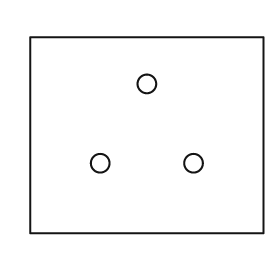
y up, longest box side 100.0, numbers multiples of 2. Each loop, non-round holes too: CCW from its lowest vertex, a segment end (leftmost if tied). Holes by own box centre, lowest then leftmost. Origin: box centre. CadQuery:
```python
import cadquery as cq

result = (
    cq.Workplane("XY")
    .moveTo(-50.0, -42.0)
    .lineTo(50.0, -42.0)
    .lineTo(50.0, 42.0)
    .lineTo(-50.0, 42.0)
    .close()
    .moveTo(-20.0, -12.0)
    .circle(4.0)
    .moveTo(20.0, -12.0)
    .circle(4.0)
    .moveTo(0.0, 22.0)
    .circle(4.0)
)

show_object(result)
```